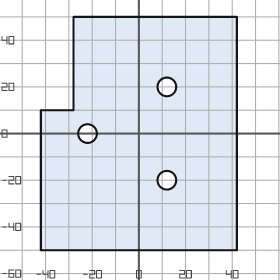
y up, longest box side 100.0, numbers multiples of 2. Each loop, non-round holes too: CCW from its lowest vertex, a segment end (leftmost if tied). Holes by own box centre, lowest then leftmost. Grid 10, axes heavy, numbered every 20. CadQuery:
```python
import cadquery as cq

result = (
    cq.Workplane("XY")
    .moveTo(-42.0, -50.0)
    .lineTo(42.0, -50.0)
    .lineTo(42.0, 50.0)
    .lineTo(-28.0, 50.0)
    .lineTo(-28.0, 10.0)
    .lineTo(-42.0, 10.0)
    .close()
    .moveTo(12.0, -20.0)
    .circle(4.0)
    .moveTo(-22.0, 0.0)
    .circle(4.0)
    .moveTo(12.0, 20.0)
    .circle(4.0)
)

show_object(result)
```